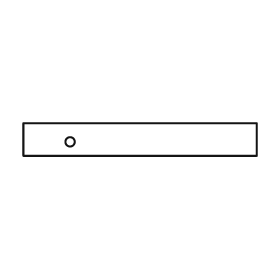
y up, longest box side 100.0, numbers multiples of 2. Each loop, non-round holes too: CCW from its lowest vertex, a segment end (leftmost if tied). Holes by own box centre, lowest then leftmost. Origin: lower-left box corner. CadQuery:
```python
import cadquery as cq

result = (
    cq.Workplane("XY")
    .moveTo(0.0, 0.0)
    .lineTo(100.0, 0.0)
    .lineTo(100.0, 14.0)
    .lineTo(0.0, 14.0)
    .close()
    .moveTo(20.0, 6.0)
    .circle(2.0)
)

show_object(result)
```